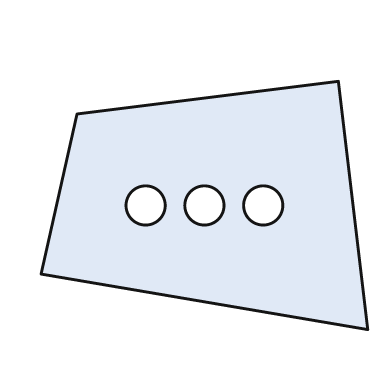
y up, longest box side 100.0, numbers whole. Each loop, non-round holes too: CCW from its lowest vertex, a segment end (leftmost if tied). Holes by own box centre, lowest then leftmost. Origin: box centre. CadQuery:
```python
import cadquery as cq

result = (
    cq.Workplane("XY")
    .moveTo(50.0, -38.0)
    .lineTo(41.0, 38.0)
    .lineTo(-39.0, 28.0)
    .lineTo(-50.0, -21.0)
    .close()
    .moveTo(-18.0, 0.0)
    .circle(6.0)
    .moveTo(0.0, 0.0)
    .circle(6.0)
    .moveTo(18.0, 0.0)
    .circle(6.0)
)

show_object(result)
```